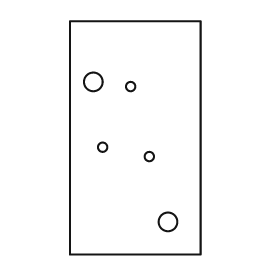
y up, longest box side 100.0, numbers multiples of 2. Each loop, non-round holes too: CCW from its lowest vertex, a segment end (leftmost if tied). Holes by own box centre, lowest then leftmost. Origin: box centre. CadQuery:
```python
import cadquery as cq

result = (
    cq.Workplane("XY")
    .moveTo(-28.0, -50.0)
    .lineTo(28.0, -50.0)
    .lineTo(28.0, 50.0)
    .lineTo(-28.0, 50.0)
    .close()
    .moveTo(14.0, -36.0)
    .circle(4.0)
    .moveTo(6.0, -8.0)
    .circle(2.0)
    .moveTo(-14.0, -4.0)
    .circle(2.0)
    .moveTo(-2.0, 22.0)
    .circle(2.0)
    .moveTo(-18.0, 24.0)
    .circle(4.0)
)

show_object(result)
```